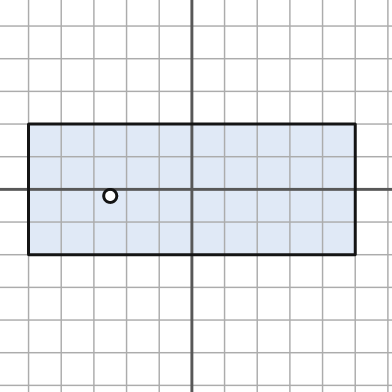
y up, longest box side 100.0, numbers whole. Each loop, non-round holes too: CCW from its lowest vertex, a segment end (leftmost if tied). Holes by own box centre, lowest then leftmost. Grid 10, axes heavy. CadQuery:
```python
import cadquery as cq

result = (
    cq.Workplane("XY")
    .moveTo(-50.0, -20.0)
    .lineTo(50.0, -20.0)
    .lineTo(50.0, 20.0)
    .lineTo(-50.0, 20.0)
    .close()
    .moveTo(-25.0, -2.0)
    .circle(2.0)
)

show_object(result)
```